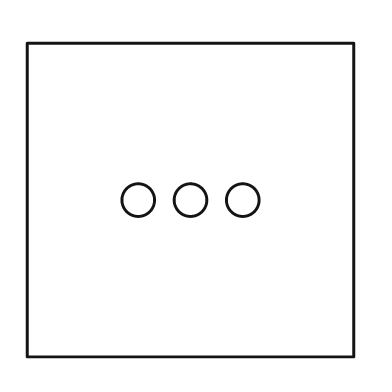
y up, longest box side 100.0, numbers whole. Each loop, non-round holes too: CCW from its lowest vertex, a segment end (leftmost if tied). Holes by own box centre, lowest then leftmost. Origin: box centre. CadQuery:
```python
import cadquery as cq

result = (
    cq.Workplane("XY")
    .moveTo(-50.0, -48.0)
    .lineTo(50.0, -48.0)
    .lineTo(50.0, 48.0)
    .lineTo(-50.0, 48.0)
    .close()
    .moveTo(-16.0, 0.0)
    .circle(5.0)
    .moveTo(0.0, 0.0)
    .circle(5.0)
    .moveTo(16.0, 0.0)
    .circle(5.0)
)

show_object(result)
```